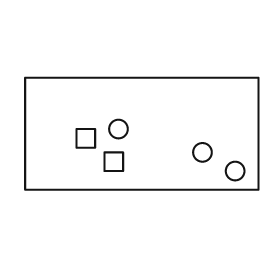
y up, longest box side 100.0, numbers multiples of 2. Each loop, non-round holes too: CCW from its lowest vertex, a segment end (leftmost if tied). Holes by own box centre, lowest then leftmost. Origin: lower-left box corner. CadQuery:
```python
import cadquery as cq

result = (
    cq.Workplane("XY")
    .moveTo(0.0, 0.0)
    .lineTo(100.0, 0.0)
    .lineTo(100.0, 48.0)
    .lineTo(0.0, 48.0)
    .close()
    .moveTo(90.0, 8.0)
    .circle(4.0)
    .moveTo(34.0, 8.0)
    .lineTo(42.0, 8.0)
    .lineTo(42.0, 16.0)
    .lineTo(34.0, 16.0)
    .close()
    .moveTo(76.0, 16.0)
    .circle(4.0)
    .moveTo(22.0, 18.0)
    .lineTo(30.0, 18.0)
    .lineTo(30.0, 26.0)
    .lineTo(22.0, 26.0)
    .close()
    .moveTo(40.0, 26.0)
    .circle(4.0)
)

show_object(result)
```